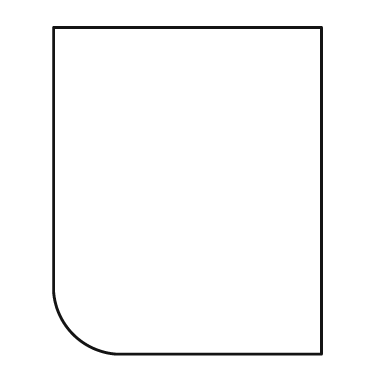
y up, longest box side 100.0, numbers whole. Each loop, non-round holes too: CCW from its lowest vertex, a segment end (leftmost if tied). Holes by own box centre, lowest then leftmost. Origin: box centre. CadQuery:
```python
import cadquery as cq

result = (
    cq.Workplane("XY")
    .moveTo(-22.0, -50.0)
    .lineTo(41.0, -50.0)
    .lineTo(41.0, 50.0)
    .lineTo(-41.0, 50.0)
    .lineTo(-41.0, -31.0)
    .threePointArc((-35.0, -44.0), (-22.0, -50.0))
    .close()
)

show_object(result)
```